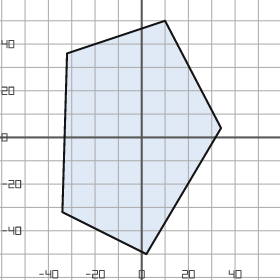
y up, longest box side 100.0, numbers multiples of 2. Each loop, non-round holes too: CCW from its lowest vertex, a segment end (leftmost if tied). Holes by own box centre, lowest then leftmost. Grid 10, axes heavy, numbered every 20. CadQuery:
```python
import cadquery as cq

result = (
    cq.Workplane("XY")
    .moveTo(2.0, -50.0)
    .lineTo(34.0, 4.0)
    .lineTo(10.0, 50.0)
    .lineTo(-32.0, 36.0)
    .lineTo(-34.0, -32.0)
    .close()
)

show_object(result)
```